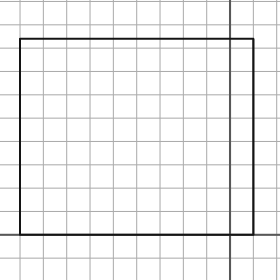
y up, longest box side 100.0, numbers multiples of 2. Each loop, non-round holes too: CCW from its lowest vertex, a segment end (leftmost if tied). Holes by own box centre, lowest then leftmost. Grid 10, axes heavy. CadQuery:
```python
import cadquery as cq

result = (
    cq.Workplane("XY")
    .moveTo(-90.0, 0.0)
    .lineTo(10.0, 0.0)
    .lineTo(10.0, 84.0)
    .lineTo(-90.0, 84.0)
    .close()
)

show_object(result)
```